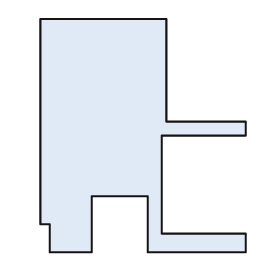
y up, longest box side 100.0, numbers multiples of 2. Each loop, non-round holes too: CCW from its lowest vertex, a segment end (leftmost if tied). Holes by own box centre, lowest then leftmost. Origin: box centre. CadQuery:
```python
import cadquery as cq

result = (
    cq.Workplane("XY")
    .moveTo(-40.0, -50.0)
    .lineTo(-22.0, -50.0)
    .lineTo(-22.0, -26.0)
    .lineTo(2.0, -26.0)
    .lineTo(2.0, -50.0)
    .lineTo(44.0, -50.0)
    .lineTo(44.0, -42.0)
    .lineTo(8.0, -42.0)
    .lineTo(8.0, 0.0)
    .lineTo(44.0, 0.0)
    .lineTo(44.0, 6.0)
    .lineTo(10.0, 6.0)
    .lineTo(10.0, 50.0)
    .lineTo(-44.0, 50.0)
    .lineTo(-44.0, -38.0)
    .lineTo(-40.0, -38.0)
    .close()
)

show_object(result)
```